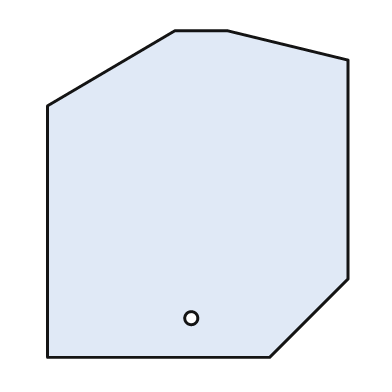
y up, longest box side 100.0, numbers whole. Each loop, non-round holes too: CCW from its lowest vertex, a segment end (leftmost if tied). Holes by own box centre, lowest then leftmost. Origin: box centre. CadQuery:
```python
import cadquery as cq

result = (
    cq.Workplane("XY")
    .moveTo(-46.0, -50.0)
    .lineTo(22.0, -50.0)
    .lineTo(46.0, -26.0)
    .lineTo(46.0, 41.0)
    .lineTo(9.0, 50.0)
    .lineTo(-7.0, 50.0)
    .lineTo(-46.0, 27.0)
    .close()
    .moveTo(-2.0, -38.0)
    .circle(2.0)
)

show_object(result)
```